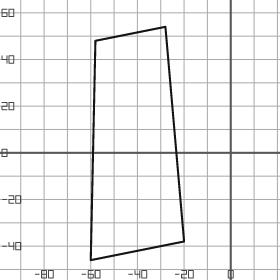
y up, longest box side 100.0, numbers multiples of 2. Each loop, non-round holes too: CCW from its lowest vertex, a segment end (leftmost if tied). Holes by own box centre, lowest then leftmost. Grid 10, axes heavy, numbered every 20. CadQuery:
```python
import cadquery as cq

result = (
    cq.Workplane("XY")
    .moveTo(-60.0, -46.0)
    .lineTo(-20.0, -38.0)
    .lineTo(-28.0, 54.0)
    .lineTo(-58.0, 48.0)
    .close()
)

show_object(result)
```